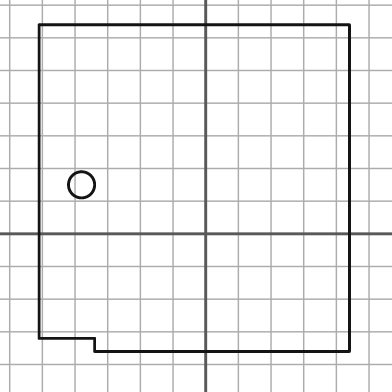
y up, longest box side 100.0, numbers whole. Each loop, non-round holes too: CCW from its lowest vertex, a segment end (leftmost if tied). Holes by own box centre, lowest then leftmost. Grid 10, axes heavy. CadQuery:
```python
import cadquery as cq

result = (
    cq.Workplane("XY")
    .moveTo(-34.0, -36.0)
    .lineTo(44.0, -36.0)
    .lineTo(44.0, 64.0)
    .lineTo(-51.0, 64.0)
    .lineTo(-51.0, -32.0)
    .lineTo(-34.0, -32.0)
    .close()
    .moveTo(-38.0, 15.0)
    .circle(4.0)
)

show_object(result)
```